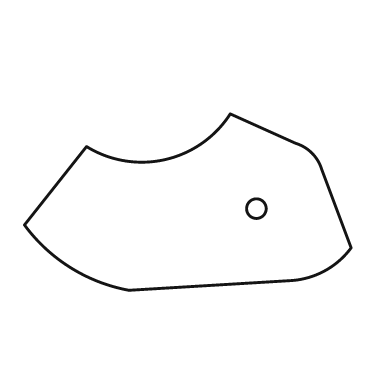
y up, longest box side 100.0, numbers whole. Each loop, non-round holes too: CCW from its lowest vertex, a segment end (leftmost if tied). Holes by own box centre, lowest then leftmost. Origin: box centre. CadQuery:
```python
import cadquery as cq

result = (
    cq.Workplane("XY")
    .moveTo(-18.0, -27.0)
    .lineTo(32.0, -24.0)
    .threePointArc((42.0, -21.0), (50.0, -14.0))
    .lineTo(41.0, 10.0)
    .threePointArc((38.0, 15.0), (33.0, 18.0))
    .lineTo(13.0, 27.0)
    .threePointArc((-7.0, 13.0), (-31.0, 17.0))
    .lineTo(-50.0, -7.0)
    .threePointArc((-36.0, -20.0), (-18.0, -27.0))
    .close()
    .moveTo(21.0, -2.0)
    .circle(3.0)
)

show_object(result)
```